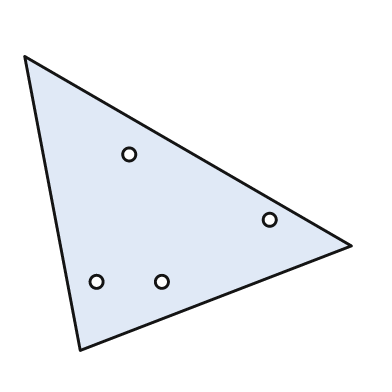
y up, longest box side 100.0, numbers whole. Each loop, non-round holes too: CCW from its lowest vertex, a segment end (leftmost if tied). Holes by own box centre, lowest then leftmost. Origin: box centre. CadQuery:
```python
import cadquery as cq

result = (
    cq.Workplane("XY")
    .moveTo(-33.0, -45.0)
    .lineTo(50.0, -13.0)
    .lineTo(-50.0, 45.0)
    .close()
    .moveTo(-28.0, -24.0)
    .circle(2.0)
    .moveTo(-8.0, -24.0)
    .circle(2.0)
    .moveTo(25.0, -5.0)
    .circle(2.0)
    .moveTo(-18.0, 15.0)
    .circle(2.0)
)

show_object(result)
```